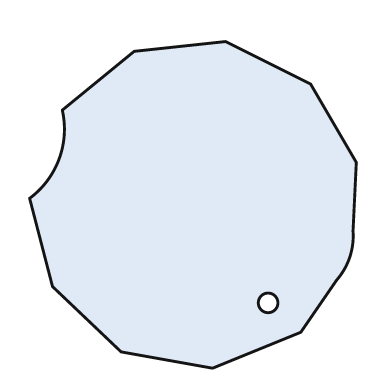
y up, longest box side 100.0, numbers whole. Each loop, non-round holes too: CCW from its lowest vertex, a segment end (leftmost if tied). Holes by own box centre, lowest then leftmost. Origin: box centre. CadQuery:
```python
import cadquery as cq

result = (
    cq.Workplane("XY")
    .moveTo(6.0, -50.0)
    .lineTo(33.0, -39.0)
    .lineTo(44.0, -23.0)
    .threePointArc((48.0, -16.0), (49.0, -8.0))
    .lineTo(50.0, 13.0)
    .lineTo(36.0, 37.0)
    .lineTo(10.0, 50.0)
    .lineTo(-18.0, 47.0)
    .lineTo(-40.0, 29.0)
    .threePointArc((-41.0, 14.0), (-50.0, 2.0))
    .lineTo(-43.0, -25.0)
    .lineTo(-22.0, -45.0)
    .close()
    .moveTo(23.0, -30.0)
    .circle(3.0)
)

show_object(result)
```